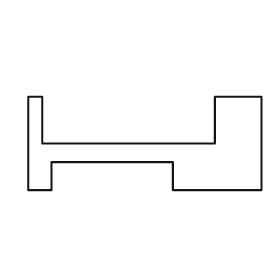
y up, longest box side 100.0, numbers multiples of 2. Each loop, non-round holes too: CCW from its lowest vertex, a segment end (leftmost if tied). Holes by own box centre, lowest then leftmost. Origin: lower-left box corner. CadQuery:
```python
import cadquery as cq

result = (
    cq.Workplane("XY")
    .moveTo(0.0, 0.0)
    .lineTo(10.0, 0.0)
    .lineTo(10.0, 12.0)
    .lineTo(62.0, 12.0)
    .lineTo(62.0, 0.0)
    .lineTo(100.0, 0.0)
    .lineTo(100.0, 40.0)
    .lineTo(80.0, 40.0)
    .lineTo(80.0, 20.0)
    .lineTo(6.0, 20.0)
    .lineTo(6.0, 40.0)
    .lineTo(0.0, 40.0)
    .close()
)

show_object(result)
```